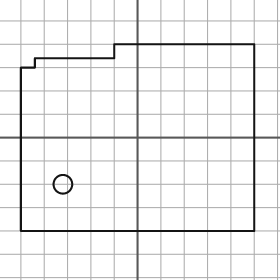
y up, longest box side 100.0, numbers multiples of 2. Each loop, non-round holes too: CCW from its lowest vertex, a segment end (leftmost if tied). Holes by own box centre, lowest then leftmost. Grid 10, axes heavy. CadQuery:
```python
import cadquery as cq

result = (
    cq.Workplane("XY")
    .moveTo(-50.0, -40.0)
    .lineTo(50.0, -40.0)
    .lineTo(50.0, 40.0)
    .lineTo(-10.0, 40.0)
    .lineTo(-10.0, 34.0)
    .lineTo(-44.0, 34.0)
    .lineTo(-44.0, 30.0)
    .lineTo(-50.0, 30.0)
    .close()
    .moveTo(-32.0, -20.0)
    .circle(4.0)
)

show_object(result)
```